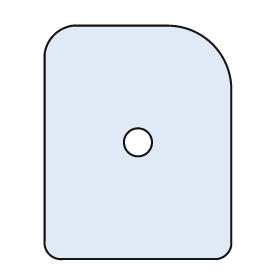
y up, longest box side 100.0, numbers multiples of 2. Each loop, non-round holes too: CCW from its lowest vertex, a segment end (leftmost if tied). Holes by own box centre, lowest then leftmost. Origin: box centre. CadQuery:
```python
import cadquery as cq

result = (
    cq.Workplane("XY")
    .moveTo(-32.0, -50.0)
    .lineTo(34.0, -50.0)
    .threePointArc((38.0, -48.0), (40.0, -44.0))
    .lineTo(40.0, 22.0)
    .threePointArc((32.0, 42.0), (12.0, 50.0))
    .lineTo(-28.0, 50.0)
    .threePointArc((-36.0, 46.0), (-40.0, 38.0))
    .lineTo(-40.0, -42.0)
    .threePointArc((-38.0, -48.0), (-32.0, -50.0))
    .close()
    .moveTo(0.0, 0.0)
    .circle(6.0)
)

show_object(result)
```